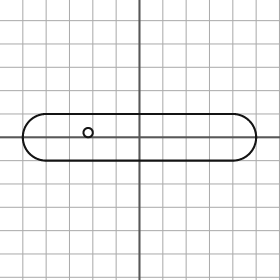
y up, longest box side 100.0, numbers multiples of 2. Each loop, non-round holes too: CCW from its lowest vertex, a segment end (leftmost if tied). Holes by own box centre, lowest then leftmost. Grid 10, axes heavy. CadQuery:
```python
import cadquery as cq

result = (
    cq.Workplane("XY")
    .moveTo(-40.0, -10.0)
    .lineTo(40.0, -10.0)
    .threePointArc((50.0, 0.0), (40.0, 10.0))
    .lineTo(-40.0, 10.0)
    .threePointArc((-50.0, 0.0), (-40.0, -10.0))
    .close()
    .moveTo(-22.0, 2.0)
    .circle(2.0)
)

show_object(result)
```